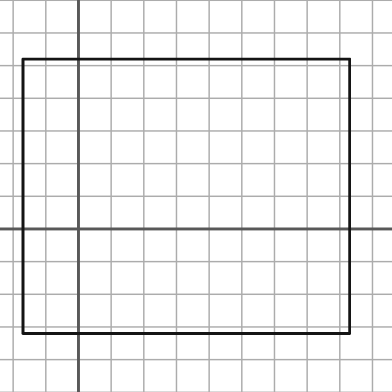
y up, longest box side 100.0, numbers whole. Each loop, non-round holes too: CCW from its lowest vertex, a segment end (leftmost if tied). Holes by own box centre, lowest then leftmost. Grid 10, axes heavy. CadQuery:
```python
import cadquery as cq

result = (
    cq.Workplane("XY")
    .moveTo(-17.0, -32.0)
    .lineTo(83.0, -32.0)
    .lineTo(83.0, 52.0)
    .lineTo(-17.0, 52.0)
    .close()
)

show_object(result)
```